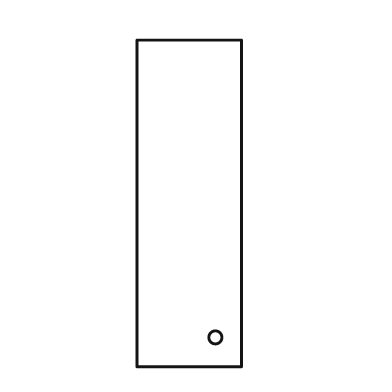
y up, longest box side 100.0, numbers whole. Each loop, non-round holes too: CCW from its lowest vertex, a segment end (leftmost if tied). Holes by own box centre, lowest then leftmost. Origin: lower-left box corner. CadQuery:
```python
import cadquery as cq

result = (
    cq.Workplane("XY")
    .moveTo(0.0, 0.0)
    .lineTo(32.0, 0.0)
    .lineTo(32.0, 100.0)
    .lineTo(0.0, 100.0)
    .close()
    .moveTo(24.0, 9.0)
    .circle(2.0)
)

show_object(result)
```